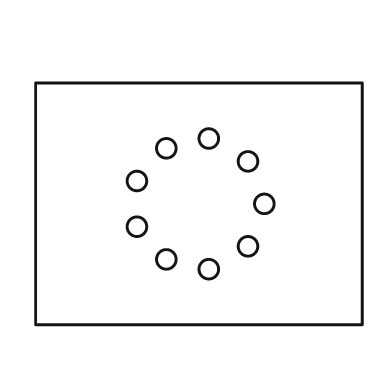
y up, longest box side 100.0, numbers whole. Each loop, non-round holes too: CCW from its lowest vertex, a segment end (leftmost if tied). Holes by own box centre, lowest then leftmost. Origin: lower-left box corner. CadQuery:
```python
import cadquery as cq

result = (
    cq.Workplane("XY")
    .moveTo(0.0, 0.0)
    .lineTo(100.0, 0.0)
    .lineTo(100.0, 74.0)
    .lineTo(0.0, 74.0)
    .close()
    .moveTo(53.0, 17.0)
    .circle(3.0)
    .moveTo(40.0, 20.0)
    .circle(3.0)
    .moveTo(65.0, 24.0)
    .circle(3.0)
    .moveTo(31.0, 30.0)
    .circle(3.0)
    .moveTo(70.0, 37.0)
    .circle(3.0)
    .moveTo(31.0, 44.0)
    .circle(3.0)
    .moveTo(65.0, 50.0)
    .circle(3.0)
    .moveTo(40.0, 54.0)
    .circle(3.0)
    .moveTo(53.0, 57.0)
    .circle(3.0)
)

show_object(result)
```